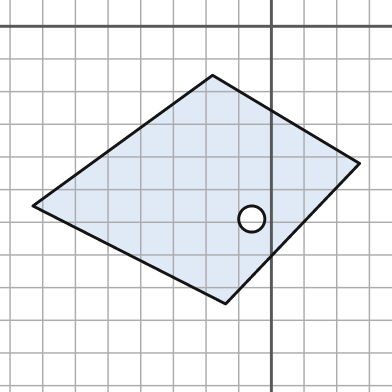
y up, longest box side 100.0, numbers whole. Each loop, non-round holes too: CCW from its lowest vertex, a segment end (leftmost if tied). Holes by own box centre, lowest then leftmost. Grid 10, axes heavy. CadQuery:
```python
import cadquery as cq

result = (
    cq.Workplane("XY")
    .moveTo(-14.0, -85.0)
    .lineTo(27.0, -42.0)
    .lineTo(-18.0, -15.0)
    .lineTo(-73.0, -55.0)
    .close()
    .moveTo(-6.0, -59.0)
    .circle(4.0)
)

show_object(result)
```